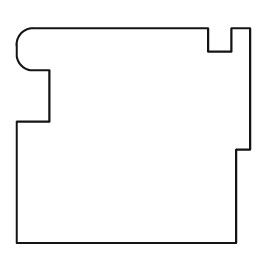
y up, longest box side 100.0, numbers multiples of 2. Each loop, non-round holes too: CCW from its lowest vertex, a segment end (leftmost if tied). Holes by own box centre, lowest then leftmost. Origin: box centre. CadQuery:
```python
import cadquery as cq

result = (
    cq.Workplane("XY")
    .moveTo(-50.0, -46.0)
    .lineTo(44.0, -46.0)
    .lineTo(44.0, -6.0)
    .lineTo(50.0, -6.0)
    .lineTo(50.0, 46.0)
    .lineTo(42.0, 46.0)
    .lineTo(42.0, 36.0)
    .lineTo(32.0, 36.0)
    .lineTo(32.0, 46.0)
    .lineTo(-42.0, 46.0)
    .threePointArc((-48.0, 44.0), (-50.0, 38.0))
    .lineTo(-50.0, 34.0)
    .threePointArc((-48.0, 30.0), (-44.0, 28.0))
    .lineTo(-36.0, 28.0)
    .lineTo(-36.0, 6.0)
    .lineTo(-50.0, 6.0)
    .close()
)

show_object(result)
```